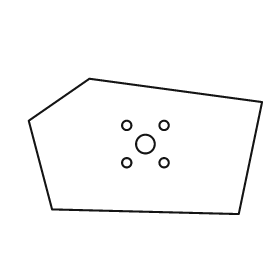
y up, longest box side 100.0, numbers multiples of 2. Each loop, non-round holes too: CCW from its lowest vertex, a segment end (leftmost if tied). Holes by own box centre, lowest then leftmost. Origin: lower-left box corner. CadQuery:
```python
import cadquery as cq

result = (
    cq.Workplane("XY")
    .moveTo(90.0, 0.0)
    .lineTo(100.0, 48.0)
    .lineTo(26.0, 58.0)
    .lineTo(0.0, 40.0)
    .lineTo(10.0, 2.0)
    .close()
    .moveTo(42.0, 22.0)
    .circle(2.0)
    .moveTo(58.0, 22.0)
    .circle(2.0)
    .moveTo(50.0, 30.0)
    .circle(4.0)
    .moveTo(42.0, 38.0)
    .circle(2.0)
    .moveTo(58.0, 38.0)
    .circle(2.0)
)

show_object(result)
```